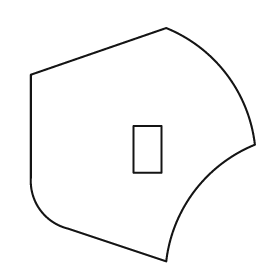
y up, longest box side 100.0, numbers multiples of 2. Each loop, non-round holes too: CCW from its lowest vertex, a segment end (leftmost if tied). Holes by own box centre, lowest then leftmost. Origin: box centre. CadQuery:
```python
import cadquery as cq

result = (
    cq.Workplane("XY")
    .moveTo(10.0, -50.0)
    .threePointArc((22.0, -20.0), (48.0, 0.0))
    .threePointArc((36.0, 30.0), (10.0, 50.0))
    .lineTo(-48.0, 30.0)
    .lineTo(-48.0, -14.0)
    .threePointArc((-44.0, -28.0), (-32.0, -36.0))
    .close()
    .moveTo(-4.0, -12.0)
    .lineTo(8.0, -12.0)
    .lineTo(8.0, 8.0)
    .lineTo(-4.0, 8.0)
    .close()
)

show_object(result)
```